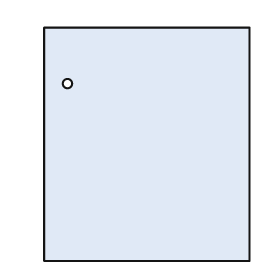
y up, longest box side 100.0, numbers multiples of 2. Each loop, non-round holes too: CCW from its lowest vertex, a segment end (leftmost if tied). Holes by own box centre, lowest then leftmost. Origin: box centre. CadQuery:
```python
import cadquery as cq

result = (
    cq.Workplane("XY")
    .moveTo(-44.0, -50.0)
    .lineTo(44.0, -50.0)
    .lineTo(44.0, 50.0)
    .lineTo(-44.0, 50.0)
    .close()
    .moveTo(-34.0, 26.0)
    .circle(2.0)
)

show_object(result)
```